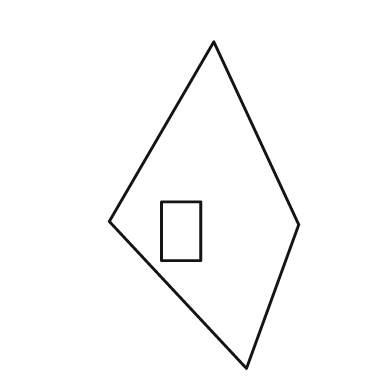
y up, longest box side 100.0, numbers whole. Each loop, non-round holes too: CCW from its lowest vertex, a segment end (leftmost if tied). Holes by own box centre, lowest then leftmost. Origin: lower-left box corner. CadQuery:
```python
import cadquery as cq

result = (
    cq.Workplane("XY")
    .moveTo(42.0, 0.0)
    .lineTo(58.0, 44.0)
    .lineTo(32.0, 100.0)
    .lineTo(0.0, 45.0)
    .close()
    .moveTo(16.0, 33.0)
    .lineTo(28.0, 33.0)
    .lineTo(28.0, 51.0)
    .lineTo(16.0, 51.0)
    .close()
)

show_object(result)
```